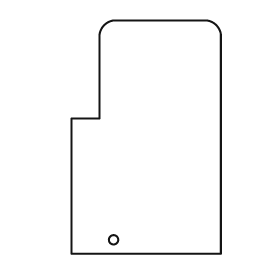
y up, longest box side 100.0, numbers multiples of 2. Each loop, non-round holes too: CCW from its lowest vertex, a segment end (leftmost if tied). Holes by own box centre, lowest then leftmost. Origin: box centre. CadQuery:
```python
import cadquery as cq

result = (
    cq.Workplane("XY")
    .moveTo(-32.0, -50.0)
    .lineTo(32.0, -50.0)
    .lineTo(32.0, 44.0)
    .threePointArc((30.0, 48.0), (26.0, 50.0))
    .lineTo(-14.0, 50.0)
    .threePointArc((-18.0, 48.0), (-20.0, 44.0))
    .lineTo(-20.0, 8.0)
    .lineTo(-32.0, 8.0)
    .close()
    .moveTo(-14.0, -44.0)
    .circle(2.0)
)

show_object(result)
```